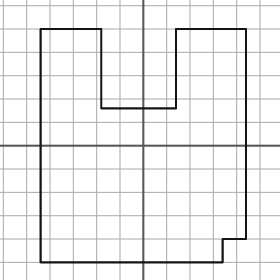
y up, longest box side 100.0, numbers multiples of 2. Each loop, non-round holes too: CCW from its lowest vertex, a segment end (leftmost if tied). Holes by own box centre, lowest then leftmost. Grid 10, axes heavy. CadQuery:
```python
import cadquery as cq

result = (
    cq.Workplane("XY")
    .moveTo(-44.0, -50.0)
    .lineTo(34.0, -50.0)
    .lineTo(34.0, -40.0)
    .lineTo(44.0, -40.0)
    .lineTo(44.0, 50.0)
    .lineTo(14.0, 50.0)
    .lineTo(14.0, 16.0)
    .lineTo(-18.0, 16.0)
    .lineTo(-18.0, 50.0)
    .lineTo(-44.0, 50.0)
    .close()
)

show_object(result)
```